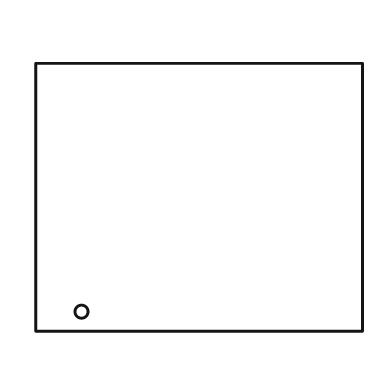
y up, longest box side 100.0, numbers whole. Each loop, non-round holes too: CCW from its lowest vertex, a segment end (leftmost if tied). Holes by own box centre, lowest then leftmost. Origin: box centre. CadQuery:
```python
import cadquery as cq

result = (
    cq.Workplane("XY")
    .moveTo(-50.0, -41.0)
    .lineTo(50.0, -41.0)
    .lineTo(50.0, 41.0)
    .lineTo(-50.0, 41.0)
    .close()
    .moveTo(-36.0, -35.0)
    .circle(2.0)
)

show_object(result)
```